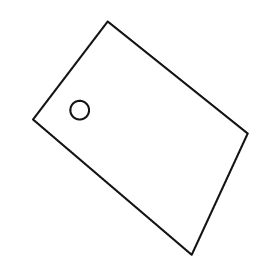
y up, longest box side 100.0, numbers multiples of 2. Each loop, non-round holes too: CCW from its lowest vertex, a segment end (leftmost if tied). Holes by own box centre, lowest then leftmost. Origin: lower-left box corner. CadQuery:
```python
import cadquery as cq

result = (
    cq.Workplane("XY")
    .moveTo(68.0, 0.0)
    .lineTo(92.0, 52.0)
    .lineTo(32.0, 100.0)
    .lineTo(0.0, 58.0)
    .close()
    .moveTo(20.0, 62.0)
    .circle(4.0)
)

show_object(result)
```